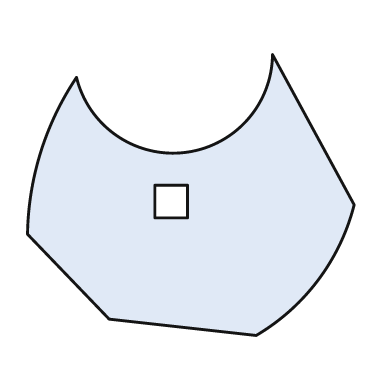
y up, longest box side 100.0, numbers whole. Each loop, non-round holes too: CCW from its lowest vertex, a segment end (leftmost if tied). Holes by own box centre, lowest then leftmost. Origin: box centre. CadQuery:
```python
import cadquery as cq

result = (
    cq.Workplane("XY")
    .moveTo(20.0, -43.0)
    .threePointArc((39.0, -26.0), (50.0, -3.0))
    .lineTo(25.0, 43.0)
    .threePointArc((-2.0, 13.0), (-35.0, 36.0))
    .threePointArc((-46.0, 13.0), (-50.0, -12.0))
    .lineTo(-25.0, -38.0)
    .close()
    .moveTo(-11.0, -7.0)
    .lineTo(-1.0, -7.0)
    .lineTo(-1.0, 3.0)
    .lineTo(-11.0, 3.0)
    .close()
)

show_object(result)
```